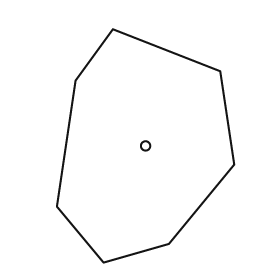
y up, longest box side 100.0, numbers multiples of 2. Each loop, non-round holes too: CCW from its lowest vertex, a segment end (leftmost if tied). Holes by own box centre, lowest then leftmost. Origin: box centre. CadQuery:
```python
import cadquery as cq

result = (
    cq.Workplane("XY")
    .moveTo(-18.0, -50.0)
    .lineTo(10.0, -42.0)
    .lineTo(38.0, -8.0)
    .lineTo(32.0, 32.0)
    .lineTo(-14.0, 50.0)
    .lineTo(-30.0, 28.0)
    .lineTo(-38.0, -26.0)
    .close()
    .moveTo(0.0, 0.0)
    .circle(2.0)
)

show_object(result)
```